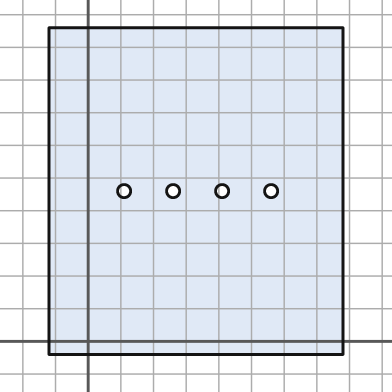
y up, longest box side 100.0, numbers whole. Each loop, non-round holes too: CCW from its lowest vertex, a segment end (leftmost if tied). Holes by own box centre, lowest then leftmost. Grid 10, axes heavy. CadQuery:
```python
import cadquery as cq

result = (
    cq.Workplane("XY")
    .moveTo(-12.0, -4.0)
    .lineTo(78.0, -4.0)
    .lineTo(78.0, 96.0)
    .lineTo(-12.0, 96.0)
    .close()
    .moveTo(11.0, 46.0)
    .circle(2.0)
    .moveTo(26.0, 46.0)
    .circle(2.0)
    .moveTo(41.0, 46.0)
    .circle(2.0)
    .moveTo(56.0, 46.0)
    .circle(2.0)
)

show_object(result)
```